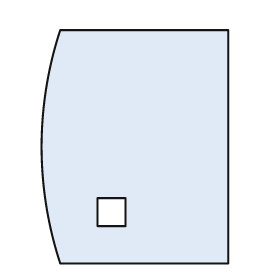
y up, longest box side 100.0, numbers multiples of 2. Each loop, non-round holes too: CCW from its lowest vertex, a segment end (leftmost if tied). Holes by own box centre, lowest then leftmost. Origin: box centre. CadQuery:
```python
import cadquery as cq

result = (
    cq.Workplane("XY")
    .moveTo(-32.0, -50.0)
    .lineTo(40.0, -50.0)
    .lineTo(40.0, 50.0)
    .lineTo(-32.0, 50.0)
    .threePointArc((-40.0, 0.0), (-32.0, -50.0))
    .close()
    .moveTo(-16.0, -34.0)
    .lineTo(-4.0, -34.0)
    .lineTo(-4.0, -22.0)
    .lineTo(-16.0, -22.0)
    .close()
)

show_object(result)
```